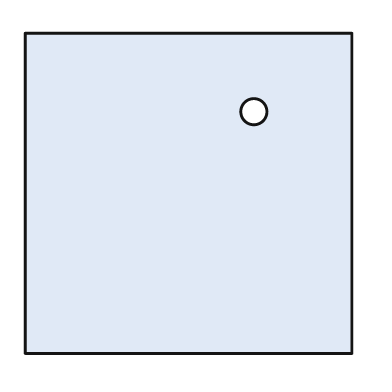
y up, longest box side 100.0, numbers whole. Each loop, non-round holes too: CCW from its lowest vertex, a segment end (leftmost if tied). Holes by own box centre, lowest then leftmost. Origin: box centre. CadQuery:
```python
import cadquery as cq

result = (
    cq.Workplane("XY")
    .moveTo(-50.0, -49.0)
    .lineTo(50.0, -49.0)
    .lineTo(50.0, 49.0)
    .lineTo(-50.0, 49.0)
    .close()
    .moveTo(20.0, 25.0)
    .circle(4.0)
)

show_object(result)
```